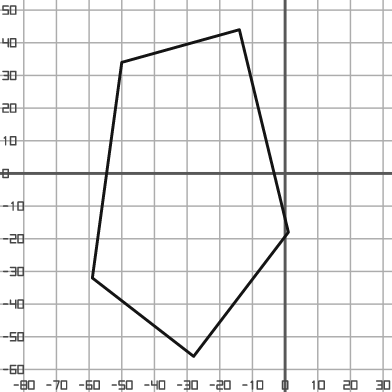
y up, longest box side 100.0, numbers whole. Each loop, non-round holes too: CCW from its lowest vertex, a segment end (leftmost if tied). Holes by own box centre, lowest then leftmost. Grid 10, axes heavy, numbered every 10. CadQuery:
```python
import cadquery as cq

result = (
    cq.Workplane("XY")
    .moveTo(-28.0, -56.0)
    .lineTo(1.0, -18.0)
    .lineTo(-14.0, 44.0)
    .lineTo(-50.0, 34.0)
    .lineTo(-59.0, -32.0)
    .close()
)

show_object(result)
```